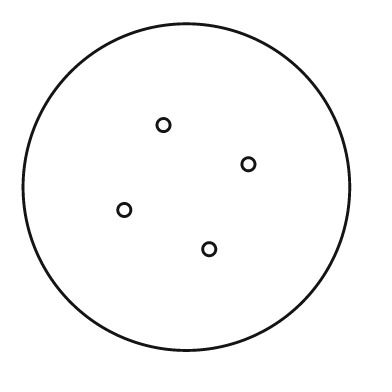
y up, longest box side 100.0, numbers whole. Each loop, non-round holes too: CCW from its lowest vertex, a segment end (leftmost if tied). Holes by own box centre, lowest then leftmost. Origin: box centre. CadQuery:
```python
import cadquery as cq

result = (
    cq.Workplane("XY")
    .moveTo(0.0, 0.0)
    .circle(50.0)
    .moveTo(7.0, -19.0)
    .circle(2.0)
    .moveTo(-19.0, -7.0)
    .circle(2.0)
    .moveTo(19.0, 7.0)
    .circle(2.0)
    .moveTo(-7.0, 19.0)
    .circle(2.0)
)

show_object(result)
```